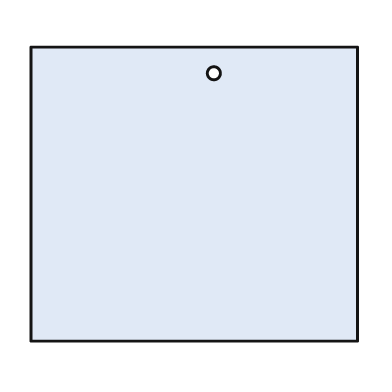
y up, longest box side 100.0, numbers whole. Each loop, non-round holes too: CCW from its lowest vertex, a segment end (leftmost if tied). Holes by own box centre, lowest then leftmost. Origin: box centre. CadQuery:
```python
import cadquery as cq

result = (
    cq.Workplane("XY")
    .moveTo(-50.0, -45.0)
    .lineTo(50.0, -45.0)
    .lineTo(50.0, 45.0)
    .lineTo(-50.0, 45.0)
    .close()
    .moveTo(6.0, 37.0)
    .circle(2.0)
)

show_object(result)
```